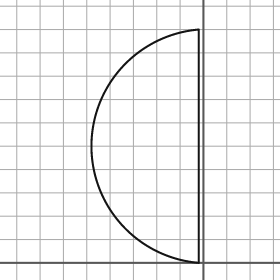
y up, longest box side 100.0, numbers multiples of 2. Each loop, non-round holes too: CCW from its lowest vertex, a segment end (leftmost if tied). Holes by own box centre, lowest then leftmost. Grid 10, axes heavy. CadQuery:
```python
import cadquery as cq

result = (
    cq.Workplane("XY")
    .moveTo(-2.0, 0.0)
    .lineTo(-2.0, 100.0)
    .threePointArc((-48.0, 50.0), (-2.0, 0.0))
    .close()
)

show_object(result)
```